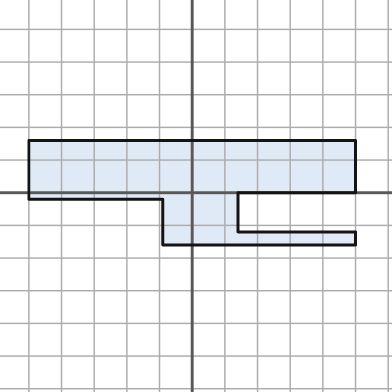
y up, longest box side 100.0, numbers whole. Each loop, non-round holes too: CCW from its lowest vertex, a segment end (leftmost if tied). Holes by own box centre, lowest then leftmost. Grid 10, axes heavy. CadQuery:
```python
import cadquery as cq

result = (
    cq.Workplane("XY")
    .moveTo(-9.0, -16.0)
    .lineTo(50.0, -16.0)
    .lineTo(50.0, -12.0)
    .lineTo(14.0, -12.0)
    .lineTo(14.0, 0.0)
    .lineTo(50.0, 0.0)
    .lineTo(50.0, 16.0)
    .lineTo(-50.0, 16.0)
    .lineTo(-50.0, -2.0)
    .lineTo(-9.0, -2.0)
    .close()
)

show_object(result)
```